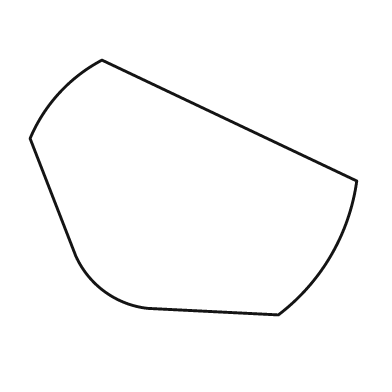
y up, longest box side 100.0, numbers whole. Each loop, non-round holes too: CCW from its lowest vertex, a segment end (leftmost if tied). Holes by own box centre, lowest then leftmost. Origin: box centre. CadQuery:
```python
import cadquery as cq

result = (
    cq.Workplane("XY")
    .moveTo(26.0, -39.0)
    .threePointArc((42.0, -21.0), (50.0, 2.0))
    .lineTo(-28.0, 39.0)
    .threePointArc((-41.0, 29.0), (-50.0, 15.0))
    .lineTo(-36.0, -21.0)
    .threePointArc((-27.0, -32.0), (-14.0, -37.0))
    .close()
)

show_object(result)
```